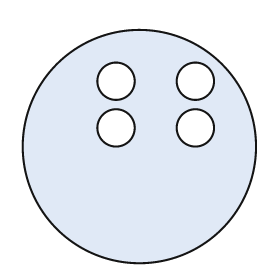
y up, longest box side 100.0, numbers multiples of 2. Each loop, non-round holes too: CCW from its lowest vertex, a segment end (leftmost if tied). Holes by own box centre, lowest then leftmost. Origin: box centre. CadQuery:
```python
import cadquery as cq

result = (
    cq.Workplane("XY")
    .moveTo(0.0, 0.0)
    .circle(50.0)
    .moveTo(-10.0, 8.0)
    .circle(8.0)
    .moveTo(24.0, 8.0)
    .circle(8.0)
    .moveTo(-10.0, 28.0)
    .circle(8.0)
    .moveTo(24.0, 28.0)
    .circle(8.0)
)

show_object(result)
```